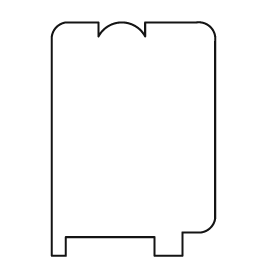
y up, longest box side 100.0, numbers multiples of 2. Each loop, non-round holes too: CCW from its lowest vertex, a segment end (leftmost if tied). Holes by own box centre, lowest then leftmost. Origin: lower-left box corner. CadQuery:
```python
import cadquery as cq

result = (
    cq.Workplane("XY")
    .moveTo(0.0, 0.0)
    .lineTo(6.0, 0.0)
    .lineTo(6.0, 8.0)
    .lineTo(44.0, 8.0)
    .lineTo(44.0, 0.0)
    .lineTo(56.0, 0.0)
    .lineTo(56.0, 10.0)
    .lineTo(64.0, 10.0)
    .threePointArc((68.0, 12.0), (70.0, 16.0))
    .lineTo(70.0, 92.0)
    .threePointArc((68.0, 98.0), (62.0, 100.0))
    .lineTo(40.0, 100.0)
    .lineTo(40.0, 94.0)
    .threePointArc((30.0, 100.0), (20.0, 94.0))
    .lineTo(20.0, 100.0)
    .lineTo(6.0, 100.0)
    .threePointArc((2.0, 98.0), (0.0, 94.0))
    .close()
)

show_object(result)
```